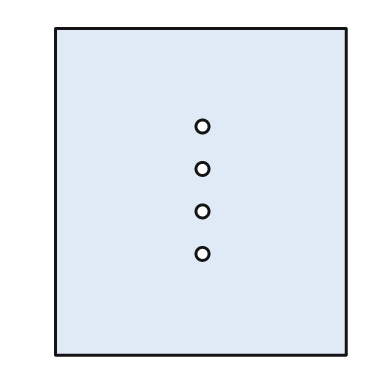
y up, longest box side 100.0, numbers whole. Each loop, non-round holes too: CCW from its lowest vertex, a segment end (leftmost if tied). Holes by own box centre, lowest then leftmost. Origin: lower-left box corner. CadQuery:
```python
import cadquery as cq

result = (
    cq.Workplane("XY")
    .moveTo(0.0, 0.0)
    .lineTo(89.0, 0.0)
    .lineTo(89.0, 100.0)
    .lineTo(0.0, 100.0)
    .close()
    .moveTo(45.0, 31.0)
    .circle(2.0)
    .moveTo(45.0, 44.0)
    .circle(2.0)
    .moveTo(45.0, 57.0)
    .circle(2.0)
    .moveTo(45.0, 70.0)
    .circle(2.0)
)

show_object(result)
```